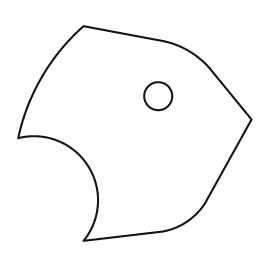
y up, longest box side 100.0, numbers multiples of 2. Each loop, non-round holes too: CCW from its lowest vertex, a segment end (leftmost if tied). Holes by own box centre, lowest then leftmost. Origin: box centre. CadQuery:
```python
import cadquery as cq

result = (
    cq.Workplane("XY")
    .moveTo(-22.0, -46.0)
    .lineTo(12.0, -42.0)
    .threePointArc((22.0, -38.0), (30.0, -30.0))
    .lineTo(50.0, 6.0)
    .lineTo(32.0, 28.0)
    .threePointArc((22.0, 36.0), (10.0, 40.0))
    .lineTo(-22.0, 46.0)
    .threePointArc((-40.0, 24.0), (-50.0, -2.0))
    .threePointArc((-20.0, -14.0), (-22.0, -46.0))
    .close()
    .moveTo(10.0, 16.0)
    .circle(6.0)
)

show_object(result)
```